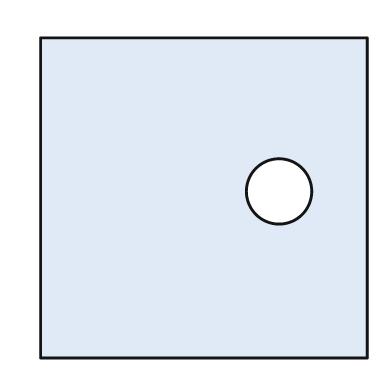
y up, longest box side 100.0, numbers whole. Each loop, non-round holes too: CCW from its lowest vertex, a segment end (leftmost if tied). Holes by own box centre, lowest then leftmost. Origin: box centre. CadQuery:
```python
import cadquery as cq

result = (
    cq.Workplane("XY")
    .moveTo(-50.0, -49.0)
    .lineTo(50.0, -49.0)
    .lineTo(50.0, 49.0)
    .lineTo(-50.0, 49.0)
    .close()
    .moveTo(23.0, 2.0)
    .circle(10.0)
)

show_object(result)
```